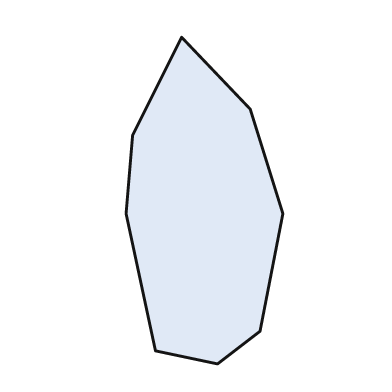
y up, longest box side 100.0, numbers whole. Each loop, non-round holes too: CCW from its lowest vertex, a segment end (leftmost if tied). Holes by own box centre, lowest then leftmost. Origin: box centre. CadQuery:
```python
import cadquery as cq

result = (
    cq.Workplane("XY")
    .moveTo(4.0, -50.0)
    .lineTo(17.0, -40.0)
    .lineTo(24.0, -4.0)
    .lineTo(14.0, 28.0)
    .lineTo(-7.0, 50.0)
    .lineTo(-22.0, 20.0)
    .lineTo(-24.0, -4.0)
    .lineTo(-15.0, -46.0)
    .close()
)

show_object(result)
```